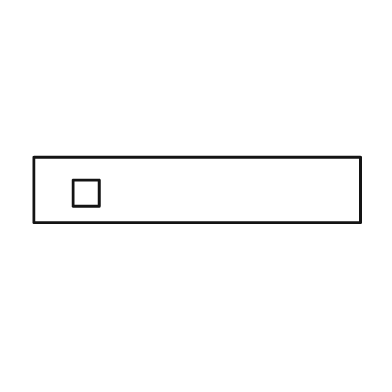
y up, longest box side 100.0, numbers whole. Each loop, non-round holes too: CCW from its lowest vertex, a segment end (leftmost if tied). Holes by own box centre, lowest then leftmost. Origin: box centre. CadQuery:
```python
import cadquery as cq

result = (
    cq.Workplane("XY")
    .moveTo(-50.0, -10.0)
    .lineTo(50.0, -10.0)
    .lineTo(50.0, 10.0)
    .lineTo(-50.0, 10.0)
    .close()
    .moveTo(-38.0, -5.0)
    .lineTo(-30.0, -5.0)
    .lineTo(-30.0, 3.0)
    .lineTo(-38.0, 3.0)
    .close()
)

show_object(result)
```